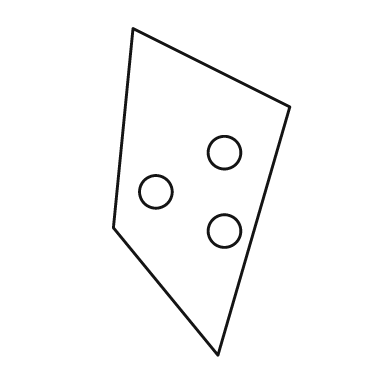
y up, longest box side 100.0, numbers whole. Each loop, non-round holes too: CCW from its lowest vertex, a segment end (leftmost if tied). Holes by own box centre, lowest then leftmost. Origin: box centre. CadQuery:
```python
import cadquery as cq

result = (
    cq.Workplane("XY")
    .moveTo(5.0, -50.0)
    .lineTo(27.0, 26.0)
    .lineTo(-21.0, 50.0)
    .lineTo(-27.0, -11.0)
    .close()
    .moveTo(7.0, -12.0)
    .circle(5.0)
    .moveTo(-14.0, 0.0)
    .circle(5.0)
    .moveTo(7.0, 12.0)
    .circle(5.0)
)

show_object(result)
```